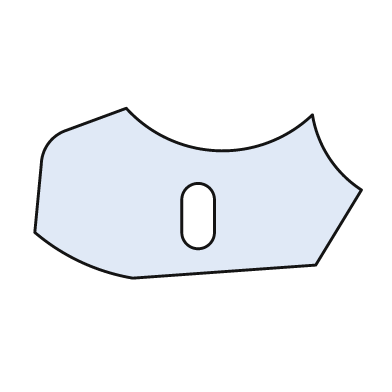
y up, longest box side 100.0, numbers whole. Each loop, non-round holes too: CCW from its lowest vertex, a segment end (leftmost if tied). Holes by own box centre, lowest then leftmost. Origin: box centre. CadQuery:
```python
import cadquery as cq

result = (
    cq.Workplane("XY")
    .moveTo(-20.0, -26.0)
    .lineTo(36.0, -22.0)
    .lineTo(50.0, 1.0)
    .threePointArc((40.0, 11.0), (35.0, 24.0))
    .threePointArc((6.0, 13.0), (-22.0, 26.0))
    .lineTo(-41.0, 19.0)
    .threePointArc((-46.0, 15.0), (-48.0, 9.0))
    .lineTo(-50.0, -12.0)
    .threePointArc((-36.0, -21.0), (-20.0, -26.0))
    .close()
    .moveTo(-5.0, -12.0)
    .threePointArc((0.0, -17.0), (5.0, -12.0))
    .lineTo(5.0, -2.0)
    .threePointArc((0.0, 3.0), (-5.0, -2.0))
    .close()
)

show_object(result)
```